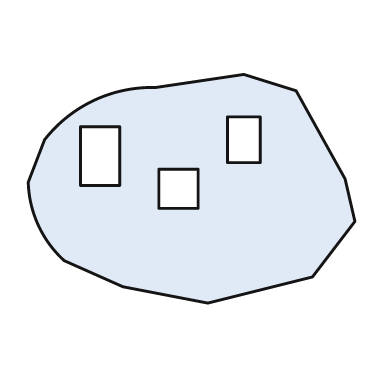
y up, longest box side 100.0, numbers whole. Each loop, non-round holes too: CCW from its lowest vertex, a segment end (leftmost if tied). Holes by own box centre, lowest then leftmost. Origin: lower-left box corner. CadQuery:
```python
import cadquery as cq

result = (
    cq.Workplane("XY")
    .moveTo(55.0, 0.0)
    .lineTo(87.0, 8.0)
    .lineTo(100.0, 25.0)
    .lineTo(97.0, 38.0)
    .lineTo(82.0, 65.0)
    .lineTo(66.0, 70.0)
    .lineTo(39.0, 66.0)
    .threePointArc((20.0, 62.0), (5.0, 50.0))
    .lineTo(0.0, 37.0)
    .threePointArc((3.0, 24.0), (11.0, 13.0))
    .lineTo(29.0, 5.0)
    .close()
    .moveTo(40.0, 29.0)
    .lineTo(52.0, 29.0)
    .lineTo(52.0, 41.0)
    .lineTo(40.0, 41.0)
    .close()
    .moveTo(16.0, 36.0)
    .lineTo(28.0, 36.0)
    .lineTo(28.0, 54.0)
    .lineTo(16.0, 54.0)
    .close()
    .moveTo(61.0, 43.0)
    .lineTo(71.0, 43.0)
    .lineTo(71.0, 57.0)
    .lineTo(61.0, 57.0)
    .close()
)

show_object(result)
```